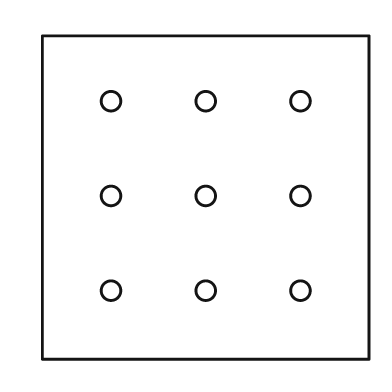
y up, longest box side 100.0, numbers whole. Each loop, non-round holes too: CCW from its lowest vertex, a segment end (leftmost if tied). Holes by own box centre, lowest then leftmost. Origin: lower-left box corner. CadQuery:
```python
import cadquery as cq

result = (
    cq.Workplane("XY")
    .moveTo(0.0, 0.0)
    .lineTo(100.0, 0.0)
    .lineTo(100.0, 99.0)
    .lineTo(0.0, 99.0)
    .close()
    .moveTo(21.0, 21.0)
    .circle(3.0)
    .moveTo(50.0, 21.0)
    .circle(3.0)
    .moveTo(79.0, 21.0)
    .circle(3.0)
    .moveTo(21.0, 50.0)
    .circle(3.0)
    .moveTo(50.0, 50.0)
    .circle(3.0)
    .moveTo(79.0, 50.0)
    .circle(3.0)
    .moveTo(21.0, 79.0)
    .circle(3.0)
    .moveTo(50.0, 79.0)
    .circle(3.0)
    .moveTo(79.0, 79.0)
    .circle(3.0)
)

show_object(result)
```